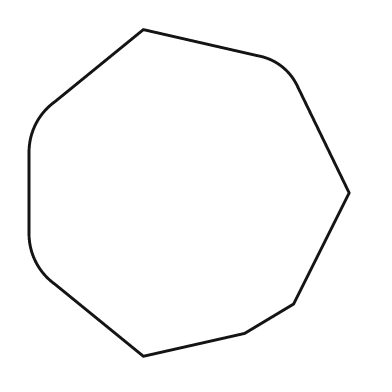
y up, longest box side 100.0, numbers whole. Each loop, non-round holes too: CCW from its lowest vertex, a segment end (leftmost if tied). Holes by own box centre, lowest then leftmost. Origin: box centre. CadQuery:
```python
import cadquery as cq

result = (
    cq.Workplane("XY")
    .moveTo(-14.0, -50.0)
    .lineTo(17.0, -43.0)
    .lineTo(32.0, -34.0)
    .lineTo(49.0, 0.0)
    .lineTo(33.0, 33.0)
    .threePointArc((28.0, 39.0), (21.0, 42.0))
    .lineTo(-14.0, 50.0)
    .lineTo(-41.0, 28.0)
    .threePointArc((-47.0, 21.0), (-49.0, 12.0))
    .lineTo(-49.0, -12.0)
    .threePointArc((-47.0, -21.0), (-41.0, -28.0))
    .close()
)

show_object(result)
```